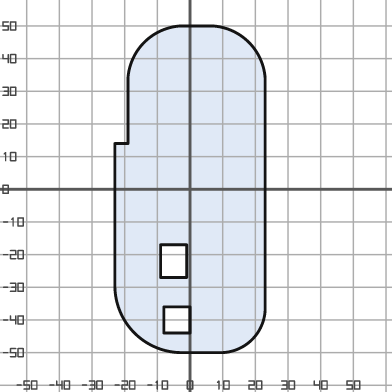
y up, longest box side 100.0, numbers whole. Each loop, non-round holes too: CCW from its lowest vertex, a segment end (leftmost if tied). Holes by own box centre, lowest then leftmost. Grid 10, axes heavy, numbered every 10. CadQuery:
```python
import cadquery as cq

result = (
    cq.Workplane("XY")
    .moveTo(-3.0, -50.0)
    .lineTo(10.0, -50.0)
    .threePointArc((19.0, -46.0), (23.0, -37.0))
    .lineTo(23.0, 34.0)
    .threePointArc((18.0, 45.0), (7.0, 50.0))
    .lineTo(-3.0, 50.0)
    .threePointArc((-14.0, 45.0), (-19.0, 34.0))
    .lineTo(-19.0, 14.0)
    .lineTo(-23.0, 14.0)
    .lineTo(-23.0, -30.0)
    .threePointArc((-17.0, -44.0), (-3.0, -50.0))
    .close()
    .moveTo(-8.0, -44.0)
    .lineTo(0.0, -44.0)
    .lineTo(0.0, -36.0)
    .lineTo(-8.0, -36.0)
    .close()
    .moveTo(-9.0, -27.0)
    .lineTo(-1.0, -27.0)
    .lineTo(-1.0, -17.0)
    .lineTo(-9.0, -17.0)
    .close()
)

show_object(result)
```